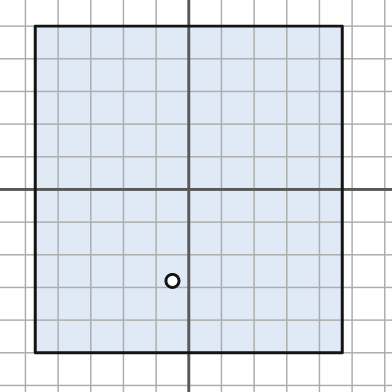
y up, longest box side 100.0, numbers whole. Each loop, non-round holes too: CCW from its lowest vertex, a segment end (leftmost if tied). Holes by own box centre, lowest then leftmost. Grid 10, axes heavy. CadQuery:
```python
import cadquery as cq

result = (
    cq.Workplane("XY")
    .moveTo(-47.0, -50.0)
    .lineTo(47.0, -50.0)
    .lineTo(47.0, 50.0)
    .lineTo(-47.0, 50.0)
    .close()
    .moveTo(-5.0, -28.0)
    .circle(2.0)
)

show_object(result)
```